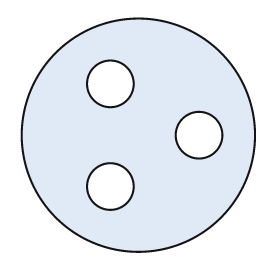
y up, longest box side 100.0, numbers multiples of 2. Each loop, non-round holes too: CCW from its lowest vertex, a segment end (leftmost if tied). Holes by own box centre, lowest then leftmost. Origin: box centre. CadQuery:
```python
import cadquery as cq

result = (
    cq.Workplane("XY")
    .moveTo(0.0, 0.0)
    .circle(50.0)
    .moveTo(-12.0, -22.0)
    .circle(10.0)
    .moveTo(26.0, 0.0)
    .circle(10.0)
    .moveTo(-12.0, 22.0)
    .circle(10.0)
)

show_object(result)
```